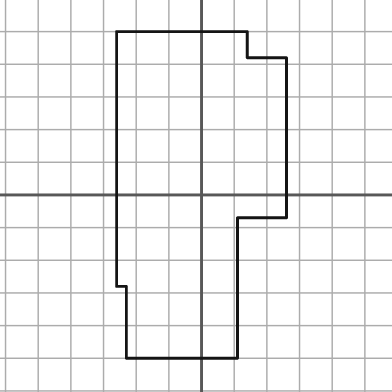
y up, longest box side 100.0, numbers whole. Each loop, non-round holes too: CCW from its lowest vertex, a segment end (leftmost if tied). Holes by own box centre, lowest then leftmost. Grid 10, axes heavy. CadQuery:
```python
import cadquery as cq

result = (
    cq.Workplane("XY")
    .moveTo(-23.0, -50.0)
    .lineTo(11.0, -50.0)
    .lineTo(11.0, -7.0)
    .lineTo(26.0, -7.0)
    .lineTo(26.0, 42.0)
    .lineTo(14.0, 42.0)
    .lineTo(14.0, 50.0)
    .lineTo(-26.0, 50.0)
    .lineTo(-26.0, -28.0)
    .lineTo(-23.0, -28.0)
    .close()
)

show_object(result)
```